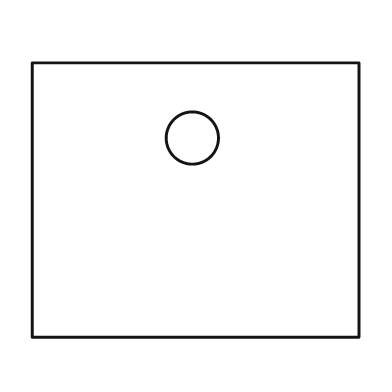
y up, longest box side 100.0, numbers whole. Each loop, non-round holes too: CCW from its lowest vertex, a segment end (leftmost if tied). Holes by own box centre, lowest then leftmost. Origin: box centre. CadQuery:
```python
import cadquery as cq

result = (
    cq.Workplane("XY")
    .moveTo(-50.0, -42.0)
    .lineTo(50.0, -42.0)
    .lineTo(50.0, 42.0)
    .lineTo(-50.0, 42.0)
    .close()
    .moveTo(-1.0, 19.0)
    .circle(8.0)
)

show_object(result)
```